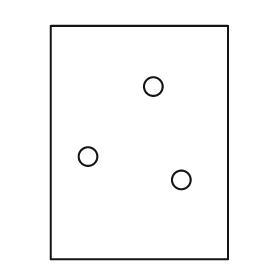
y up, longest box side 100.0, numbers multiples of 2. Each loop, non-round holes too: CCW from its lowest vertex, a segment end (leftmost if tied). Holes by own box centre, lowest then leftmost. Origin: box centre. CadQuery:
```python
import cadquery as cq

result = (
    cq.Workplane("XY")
    .moveTo(-38.0, -50.0)
    .lineTo(38.0, -50.0)
    .lineTo(38.0, 50.0)
    .lineTo(-38.0, 50.0)
    .close()
    .moveTo(18.0, -16.0)
    .circle(4.0)
    .moveTo(-22.0, -6.0)
    .circle(4.0)
    .moveTo(6.0, 24.0)
    .circle(4.0)
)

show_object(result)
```